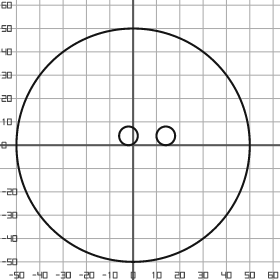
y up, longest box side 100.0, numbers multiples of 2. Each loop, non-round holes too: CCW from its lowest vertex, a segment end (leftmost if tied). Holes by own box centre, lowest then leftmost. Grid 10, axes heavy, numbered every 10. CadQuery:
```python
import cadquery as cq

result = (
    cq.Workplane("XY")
    .moveTo(0.0, 0.0)
    .circle(50.0)
    .moveTo(-2.0, 4.0)
    .circle(4.0)
    .moveTo(14.0, 4.0)
    .circle(4.0)
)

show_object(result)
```